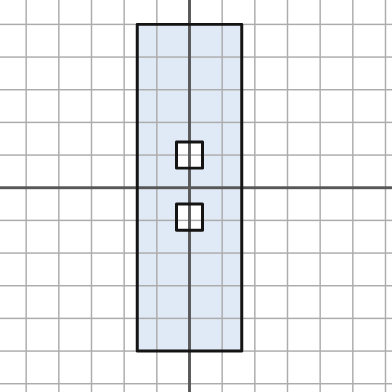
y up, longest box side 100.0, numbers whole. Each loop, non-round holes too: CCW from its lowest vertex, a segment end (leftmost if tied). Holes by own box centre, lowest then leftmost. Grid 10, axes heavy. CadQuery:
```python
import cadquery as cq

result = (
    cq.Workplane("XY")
    .moveTo(-16.0, -50.0)
    .lineTo(16.0, -50.0)
    .lineTo(16.0, 50.0)
    .lineTo(-16.0, 50.0)
    .close()
    .moveTo(-4.0, -13.0)
    .lineTo(4.0, -13.0)
    .lineTo(4.0, -5.0)
    .lineTo(-4.0, -5.0)
    .close()
    .moveTo(-4.0, 6.0)
    .lineTo(4.0, 6.0)
    .lineTo(4.0, 14.0)
    .lineTo(-4.0, 14.0)
    .close()
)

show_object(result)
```